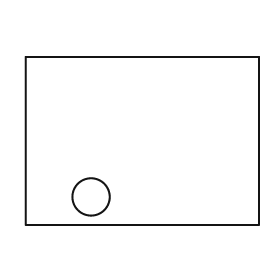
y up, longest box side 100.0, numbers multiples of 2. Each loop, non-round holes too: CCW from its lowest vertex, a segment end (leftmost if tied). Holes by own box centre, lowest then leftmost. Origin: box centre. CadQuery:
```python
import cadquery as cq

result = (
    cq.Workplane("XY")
    .moveTo(-50.0, -36.0)
    .lineTo(50.0, -36.0)
    .lineTo(50.0, 36.0)
    .lineTo(-50.0, 36.0)
    .close()
    .moveTo(-22.0, -24.0)
    .circle(8.0)
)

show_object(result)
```